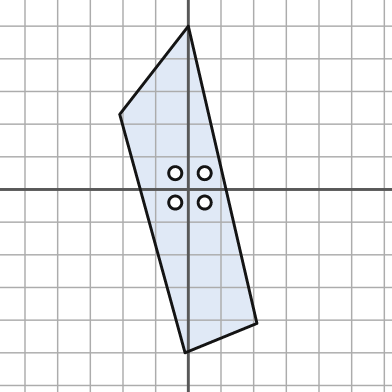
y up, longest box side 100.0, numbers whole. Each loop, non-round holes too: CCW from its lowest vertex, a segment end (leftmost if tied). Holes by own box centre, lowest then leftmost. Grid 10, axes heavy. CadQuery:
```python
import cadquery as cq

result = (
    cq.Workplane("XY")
    .moveTo(-1.0, -50.0)
    .lineTo(21.0, -41.0)
    .lineTo(0.0, 50.0)
    .lineTo(-21.0, 23.0)
    .close()
    .moveTo(-4.0, -4.0)
    .circle(2.0)
    .moveTo(5.0, -4.0)
    .circle(2.0)
    .moveTo(-4.0, 5.0)
    .circle(2.0)
    .moveTo(5.0, 5.0)
    .circle(2.0)
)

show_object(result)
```